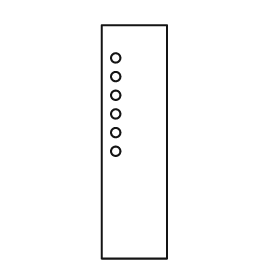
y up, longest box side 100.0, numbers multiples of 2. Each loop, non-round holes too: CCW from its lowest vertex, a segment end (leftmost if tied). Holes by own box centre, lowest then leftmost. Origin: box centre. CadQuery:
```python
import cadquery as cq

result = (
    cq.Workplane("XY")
    .moveTo(-14.0, -50.0)
    .lineTo(14.0, -50.0)
    .lineTo(14.0, 50.0)
    .lineTo(-14.0, 50.0)
    .close()
    .moveTo(-8.0, -4.0)
    .circle(2.0)
    .moveTo(-8.0, 4.0)
    .circle(2.0)
    .moveTo(-8.0, 12.0)
    .circle(2.0)
    .moveTo(-8.0, 20.0)
    .circle(2.0)
    .moveTo(-8.0, 28.0)
    .circle(2.0)
    .moveTo(-8.0, 36.0)
    .circle(2.0)
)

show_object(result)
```